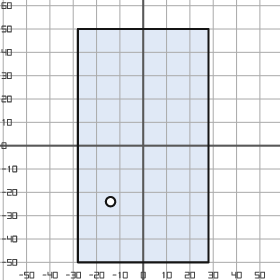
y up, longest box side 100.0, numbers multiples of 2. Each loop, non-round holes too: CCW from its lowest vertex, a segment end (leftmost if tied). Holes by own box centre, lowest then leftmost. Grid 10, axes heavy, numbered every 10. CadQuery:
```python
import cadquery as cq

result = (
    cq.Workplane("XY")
    .moveTo(-28.0, -50.0)
    .lineTo(28.0, -50.0)
    .lineTo(28.0, 50.0)
    .lineTo(-28.0, 50.0)
    .close()
    .moveTo(-14.0, -24.0)
    .circle(2.0)
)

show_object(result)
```